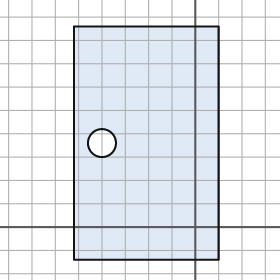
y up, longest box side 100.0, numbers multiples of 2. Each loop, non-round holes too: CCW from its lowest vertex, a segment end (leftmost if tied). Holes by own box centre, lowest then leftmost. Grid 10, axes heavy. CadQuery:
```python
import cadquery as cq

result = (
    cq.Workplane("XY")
    .moveTo(-52.0, -14.0)
    .lineTo(10.0, -14.0)
    .lineTo(10.0, 86.0)
    .lineTo(-52.0, 86.0)
    .close()
    .moveTo(-40.0, 36.0)
    .circle(6.0)
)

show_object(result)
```